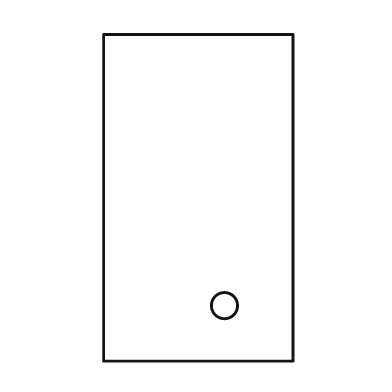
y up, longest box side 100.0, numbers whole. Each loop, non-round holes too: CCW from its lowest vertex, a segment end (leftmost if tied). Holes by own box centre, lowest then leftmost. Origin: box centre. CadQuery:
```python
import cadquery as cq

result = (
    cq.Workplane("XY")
    .moveTo(-29.0, -50.0)
    .lineTo(29.0, -50.0)
    .lineTo(29.0, 50.0)
    .lineTo(-29.0, 50.0)
    .close()
    .moveTo(8.0, -33.0)
    .circle(4.0)
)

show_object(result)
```